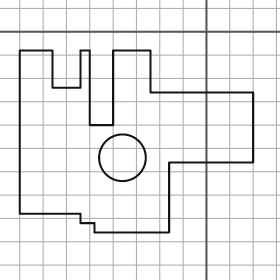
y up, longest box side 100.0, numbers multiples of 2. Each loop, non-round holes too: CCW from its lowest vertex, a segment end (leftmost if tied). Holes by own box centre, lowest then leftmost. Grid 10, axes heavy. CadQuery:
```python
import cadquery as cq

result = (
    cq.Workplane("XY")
    .moveTo(-48.0, -86.0)
    .lineTo(-16.0, -86.0)
    .lineTo(-16.0, -56.0)
    .lineTo(20.0, -56.0)
    .lineTo(20.0, -26.0)
    .lineTo(-24.0, -26.0)
    .lineTo(-24.0, -8.0)
    .lineTo(-40.0, -8.0)
    .lineTo(-40.0, -40.0)
    .lineTo(-50.0, -40.0)
    .lineTo(-50.0, -8.0)
    .lineTo(-54.0, -8.0)
    .lineTo(-54.0, -24.0)
    .lineTo(-66.0, -24.0)
    .lineTo(-66.0, -8.0)
    .lineTo(-80.0, -8.0)
    .lineTo(-80.0, -78.0)
    .lineTo(-54.0, -78.0)
    .lineTo(-54.0, -82.0)
    .lineTo(-48.0, -82.0)
    .close()
    .moveTo(-36.0, -54.0)
    .circle(10.0)
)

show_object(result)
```